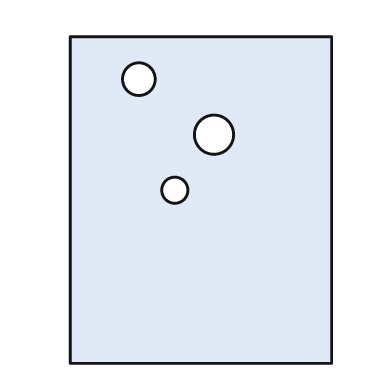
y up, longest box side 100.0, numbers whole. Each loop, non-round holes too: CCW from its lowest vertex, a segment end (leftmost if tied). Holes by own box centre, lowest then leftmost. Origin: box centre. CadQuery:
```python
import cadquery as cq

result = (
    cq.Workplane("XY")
    .moveTo(-40.0, -50.0)
    .lineTo(40.0, -50.0)
    .lineTo(40.0, 50.0)
    .lineTo(-40.0, 50.0)
    .close()
    .moveTo(-8.0, 3.0)
    .circle(4.0)
    .moveTo(4.0, 20.0)
    .circle(6.0)
    .moveTo(-19.0, 37.0)
    .circle(5.0)
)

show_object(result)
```